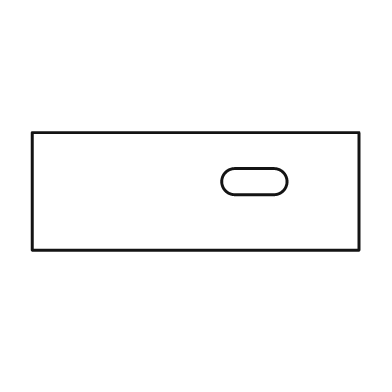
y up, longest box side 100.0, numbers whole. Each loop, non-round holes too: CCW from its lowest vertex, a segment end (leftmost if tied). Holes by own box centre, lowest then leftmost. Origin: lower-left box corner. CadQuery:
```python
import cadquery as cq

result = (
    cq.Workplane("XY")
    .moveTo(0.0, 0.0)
    .lineTo(100.0, 0.0)
    .lineTo(100.0, 36.0)
    .lineTo(0.0, 36.0)
    .close()
    .moveTo(62.0, 17.0)
    .lineTo(74.0, 17.0)
    .threePointArc((78.0, 21.0), (74.0, 25.0))
    .lineTo(62.0, 25.0)
    .threePointArc((58.0, 21.0), (62.0, 17.0))
    .close()
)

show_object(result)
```